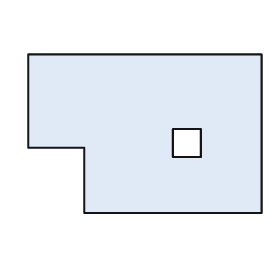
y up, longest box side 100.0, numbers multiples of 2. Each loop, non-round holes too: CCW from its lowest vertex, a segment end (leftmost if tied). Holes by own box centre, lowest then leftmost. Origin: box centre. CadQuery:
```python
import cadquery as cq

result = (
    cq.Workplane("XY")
    .moveTo(-26.0, -34.0)
    .lineTo(50.0, -34.0)
    .lineTo(50.0, 34.0)
    .lineTo(-50.0, 34.0)
    .lineTo(-50.0, -6.0)
    .lineTo(-26.0, -6.0)
    .close()
    .moveTo(12.0, -10.0)
    .lineTo(24.0, -10.0)
    .lineTo(24.0, 2.0)
    .lineTo(12.0, 2.0)
    .close()
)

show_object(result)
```